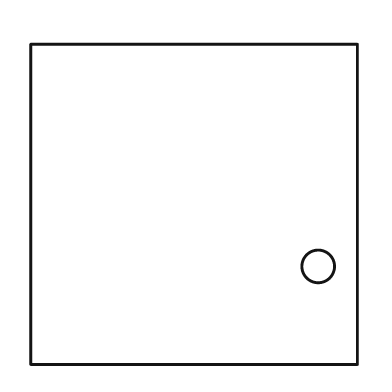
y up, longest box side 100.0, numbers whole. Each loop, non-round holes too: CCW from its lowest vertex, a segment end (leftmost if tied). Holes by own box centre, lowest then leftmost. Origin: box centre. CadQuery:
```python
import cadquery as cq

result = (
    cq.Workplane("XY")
    .moveTo(-50.0, -49.0)
    .lineTo(50.0, -49.0)
    .lineTo(50.0, 49.0)
    .lineTo(-50.0, 49.0)
    .close()
    .moveTo(38.0, -19.0)
    .circle(5.0)
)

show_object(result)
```